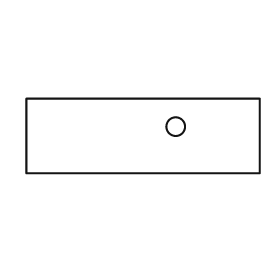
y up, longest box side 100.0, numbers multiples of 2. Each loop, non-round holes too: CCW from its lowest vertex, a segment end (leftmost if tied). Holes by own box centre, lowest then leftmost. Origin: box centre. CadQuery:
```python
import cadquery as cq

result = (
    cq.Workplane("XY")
    .moveTo(-50.0, -16.0)
    .lineTo(50.0, -16.0)
    .lineTo(50.0, 16.0)
    .lineTo(-50.0, 16.0)
    .close()
    .moveTo(14.0, 4.0)
    .circle(4.0)
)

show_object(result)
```